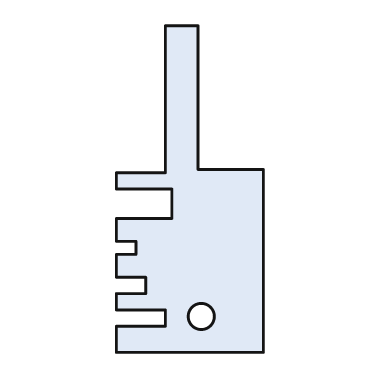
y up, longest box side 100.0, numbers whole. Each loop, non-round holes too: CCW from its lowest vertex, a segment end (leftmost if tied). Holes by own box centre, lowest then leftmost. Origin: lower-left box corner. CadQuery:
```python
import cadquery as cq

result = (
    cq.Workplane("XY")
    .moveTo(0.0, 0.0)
    .lineTo(45.0, 0.0)
    .lineTo(45.0, 56.0)
    .lineTo(25.0, 56.0)
    .lineTo(25.0, 100.0)
    .lineTo(15.0, 100.0)
    .lineTo(15.0, 55.0)
    .lineTo(0.0, 55.0)
    .lineTo(0.0, 50.0)
    .lineTo(17.0, 50.0)
    .lineTo(17.0, 41.0)
    .lineTo(0.0, 41.0)
    .lineTo(0.0, 34.0)
    .lineTo(6.0, 34.0)
    .lineTo(6.0, 30.0)
    .lineTo(0.0, 30.0)
    .lineTo(0.0, 23.0)
    .lineTo(9.0, 23.0)
    .lineTo(9.0, 18.0)
    .lineTo(0.0, 18.0)
    .lineTo(0.0, 13.0)
    .lineTo(15.0, 13.0)
    .lineTo(15.0, 8.0)
    .lineTo(0.0, 8.0)
    .close()
    .moveTo(26.0, 11.0)
    .circle(4.0)
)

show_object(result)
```